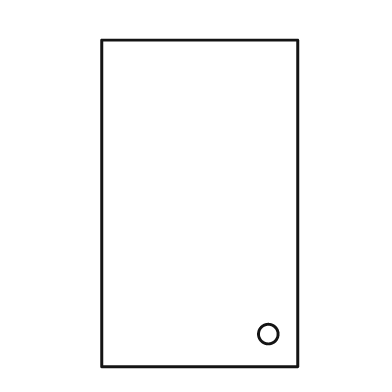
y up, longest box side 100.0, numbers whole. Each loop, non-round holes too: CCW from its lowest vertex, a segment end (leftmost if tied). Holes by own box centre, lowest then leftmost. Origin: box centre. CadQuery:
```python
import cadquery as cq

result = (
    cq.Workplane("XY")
    .moveTo(-30.0, -50.0)
    .lineTo(30.0, -50.0)
    .lineTo(30.0, 50.0)
    .lineTo(-30.0, 50.0)
    .close()
    .moveTo(21.0, -40.0)
    .circle(3.0)
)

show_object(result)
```